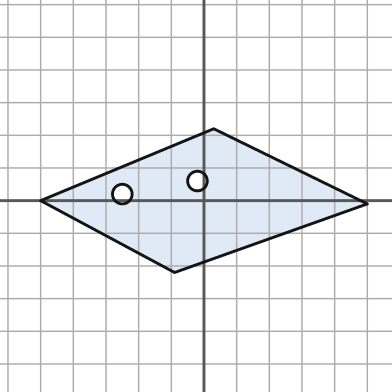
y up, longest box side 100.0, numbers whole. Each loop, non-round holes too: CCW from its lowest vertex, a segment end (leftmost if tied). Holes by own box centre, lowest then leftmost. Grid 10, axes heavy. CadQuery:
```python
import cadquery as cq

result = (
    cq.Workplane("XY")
    .moveTo(-9.0, -22.0)
    .lineTo(50.0, -1.0)
    .lineTo(3.0, 22.0)
    .lineTo(-50.0, 0.0)
    .close()
    .moveTo(-25.0, 2.0)
    .circle(3.0)
    .moveTo(-2.0, 6.0)
    .circle(3.0)
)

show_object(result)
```